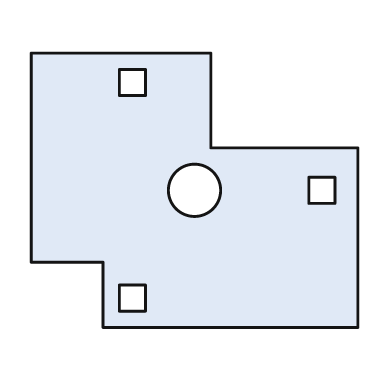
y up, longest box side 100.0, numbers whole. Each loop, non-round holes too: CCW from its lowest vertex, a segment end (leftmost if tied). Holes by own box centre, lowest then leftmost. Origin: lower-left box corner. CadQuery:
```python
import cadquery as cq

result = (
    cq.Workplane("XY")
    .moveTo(22.0, 0.0)
    .lineTo(100.0, 0.0)
    .lineTo(100.0, 55.0)
    .lineTo(55.0, 55.0)
    .lineTo(55.0, 84.0)
    .lineTo(0.0, 84.0)
    .lineTo(0.0, 20.0)
    .lineTo(22.0, 20.0)
    .close()
    .moveTo(27.0, 5.0)
    .lineTo(35.0, 5.0)
    .lineTo(35.0, 13.0)
    .lineTo(27.0, 13.0)
    .close()
    .moveTo(50.0, 42.0)
    .circle(8.0)
    .moveTo(85.0, 38.0)
    .lineTo(93.0, 38.0)
    .lineTo(93.0, 46.0)
    .lineTo(85.0, 46.0)
    .close()
    .moveTo(27.0, 71.0)
    .lineTo(35.0, 71.0)
    .lineTo(35.0, 79.0)
    .lineTo(27.0, 79.0)
    .close()
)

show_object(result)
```